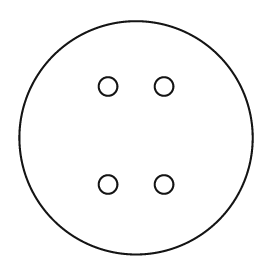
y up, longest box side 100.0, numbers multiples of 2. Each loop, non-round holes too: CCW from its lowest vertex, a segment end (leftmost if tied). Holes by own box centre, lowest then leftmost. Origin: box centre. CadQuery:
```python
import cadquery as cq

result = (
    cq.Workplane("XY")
    .moveTo(0.0, 0.0)
    .circle(50.0)
    .moveTo(-12.0, -20.0)
    .circle(4.0)
    .moveTo(12.0, -20.0)
    .circle(4.0)
    .moveTo(-12.0, 22.0)
    .circle(4.0)
    .moveTo(12.0, 22.0)
    .circle(4.0)
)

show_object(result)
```